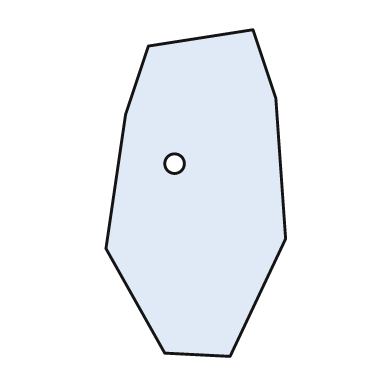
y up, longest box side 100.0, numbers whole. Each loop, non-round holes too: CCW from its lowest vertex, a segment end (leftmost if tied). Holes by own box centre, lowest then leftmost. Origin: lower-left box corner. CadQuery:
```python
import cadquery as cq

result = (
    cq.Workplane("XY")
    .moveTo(38.0, 0.0)
    .lineTo(55.0, 36.0)
    .lineTo(52.0, 79.0)
    .lineTo(45.0, 100.0)
    .lineTo(13.0, 95.0)
    .lineTo(6.0, 74.0)
    .lineTo(0.0, 33.0)
    .lineTo(18.0, 1.0)
    .close()
    .moveTo(21.0, 59.0)
    .circle(3.0)
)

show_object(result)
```